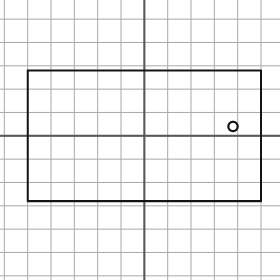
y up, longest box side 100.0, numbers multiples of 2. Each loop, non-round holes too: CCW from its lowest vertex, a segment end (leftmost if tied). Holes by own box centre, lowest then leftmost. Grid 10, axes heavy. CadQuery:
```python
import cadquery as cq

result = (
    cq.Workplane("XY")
    .moveTo(-50.0, -28.0)
    .lineTo(50.0, -28.0)
    .lineTo(50.0, 28.0)
    .lineTo(-50.0, 28.0)
    .close()
    .moveTo(38.0, 4.0)
    .circle(2.0)
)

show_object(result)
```